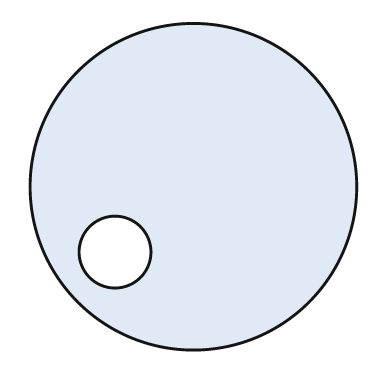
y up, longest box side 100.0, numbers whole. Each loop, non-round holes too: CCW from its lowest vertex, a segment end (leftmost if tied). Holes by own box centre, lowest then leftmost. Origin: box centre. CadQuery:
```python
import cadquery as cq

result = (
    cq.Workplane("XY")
    .moveTo(0.0, 0.0)
    .circle(50.0)
    .moveTo(-24.0, -20.0)
    .circle(11.0)
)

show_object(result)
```